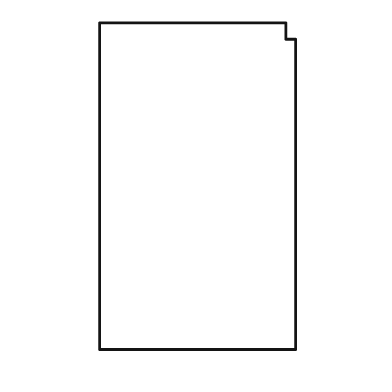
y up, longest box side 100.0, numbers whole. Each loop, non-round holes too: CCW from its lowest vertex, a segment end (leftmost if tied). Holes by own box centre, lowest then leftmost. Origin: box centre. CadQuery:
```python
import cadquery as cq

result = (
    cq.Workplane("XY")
    .moveTo(-30.0, -50.0)
    .lineTo(30.0, -50.0)
    .lineTo(30.0, 45.0)
    .lineTo(27.0, 45.0)
    .lineTo(27.0, 50.0)
    .lineTo(-30.0, 50.0)
    .close()
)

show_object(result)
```